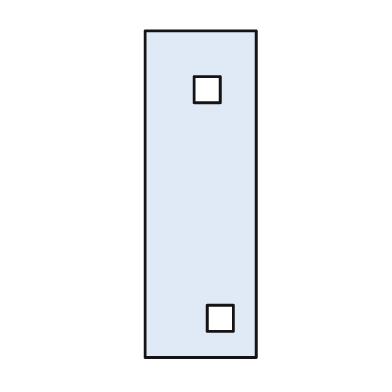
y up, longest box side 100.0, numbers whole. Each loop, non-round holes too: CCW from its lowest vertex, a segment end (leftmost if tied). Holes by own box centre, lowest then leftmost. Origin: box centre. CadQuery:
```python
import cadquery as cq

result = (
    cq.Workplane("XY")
    .moveTo(-17.0, -50.0)
    .lineTo(17.0, -50.0)
    .lineTo(17.0, 50.0)
    .lineTo(-17.0, 50.0)
    .close()
    .moveTo(2.0, -42.0)
    .lineTo(10.0, -42.0)
    .lineTo(10.0, -34.0)
    .lineTo(2.0, -34.0)
    .close()
    .moveTo(-2.0, 28.0)
    .lineTo(6.0, 28.0)
    .lineTo(6.0, 36.0)
    .lineTo(-2.0, 36.0)
    .close()
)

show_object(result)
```